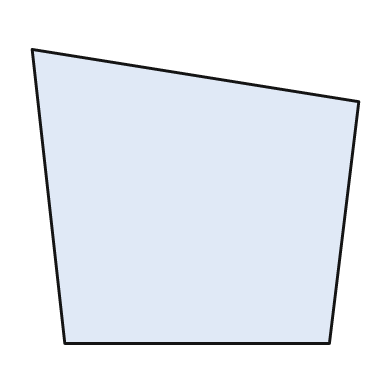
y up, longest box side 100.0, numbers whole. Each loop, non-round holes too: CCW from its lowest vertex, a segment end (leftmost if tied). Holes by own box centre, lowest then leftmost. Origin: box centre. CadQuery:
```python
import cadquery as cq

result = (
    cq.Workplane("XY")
    .moveTo(-40.0, -45.0)
    .lineTo(41.0, -45.0)
    .lineTo(50.0, 29.0)
    .lineTo(-50.0, 45.0)
    .close()
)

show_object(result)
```